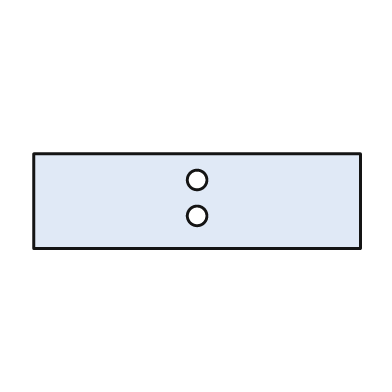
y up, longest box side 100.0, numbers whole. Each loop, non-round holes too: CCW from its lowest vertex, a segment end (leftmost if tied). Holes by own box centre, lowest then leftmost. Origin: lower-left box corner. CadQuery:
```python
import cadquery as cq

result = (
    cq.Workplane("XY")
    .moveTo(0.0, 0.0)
    .lineTo(100.0, 0.0)
    .lineTo(100.0, 29.0)
    .lineTo(0.0, 29.0)
    .close()
    .moveTo(50.0, 10.0)
    .circle(3.0)
    .moveTo(50.0, 21.0)
    .circle(3.0)
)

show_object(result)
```